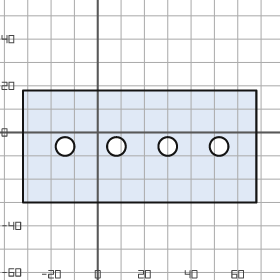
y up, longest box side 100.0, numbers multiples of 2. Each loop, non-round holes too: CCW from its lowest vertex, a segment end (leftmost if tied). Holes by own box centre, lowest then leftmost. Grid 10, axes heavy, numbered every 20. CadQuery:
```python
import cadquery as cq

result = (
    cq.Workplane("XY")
    .moveTo(-32.0, -30.0)
    .lineTo(68.0, -30.0)
    .lineTo(68.0, 18.0)
    .lineTo(-32.0, 18.0)
    .close()
    .moveTo(-14.0, -6.0)
    .circle(4.0)
    .moveTo(8.0, -6.0)
    .circle(4.0)
    .moveTo(30.0, -6.0)
    .circle(4.0)
    .moveTo(52.0, -6.0)
    .circle(4.0)
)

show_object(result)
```